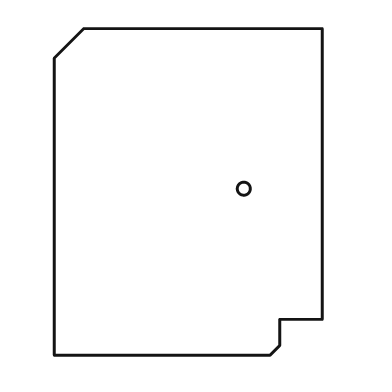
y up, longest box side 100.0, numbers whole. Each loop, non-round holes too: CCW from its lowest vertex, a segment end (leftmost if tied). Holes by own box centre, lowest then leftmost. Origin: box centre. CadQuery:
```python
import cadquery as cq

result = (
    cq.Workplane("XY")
    .moveTo(-41.0, -50.0)
    .lineTo(25.0, -50.0)
    .lineTo(28.0, -47.0)
    .lineTo(28.0, -39.0)
    .lineTo(41.0, -39.0)
    .lineTo(41.0, 50.0)
    .lineTo(-32.0, 50.0)
    .lineTo(-41.0, 41.0)
    .close()
    .moveTo(17.0, 1.0)
    .circle(2.0)
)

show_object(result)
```